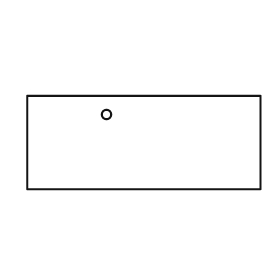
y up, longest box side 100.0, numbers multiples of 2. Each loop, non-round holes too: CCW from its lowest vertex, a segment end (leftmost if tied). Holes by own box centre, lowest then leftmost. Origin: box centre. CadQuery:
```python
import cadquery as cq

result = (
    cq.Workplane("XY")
    .moveTo(-50.0, -20.0)
    .lineTo(50.0, -20.0)
    .lineTo(50.0, 20.0)
    .lineTo(-50.0, 20.0)
    .close()
    .moveTo(-16.0, 12.0)
    .circle(2.0)
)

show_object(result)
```